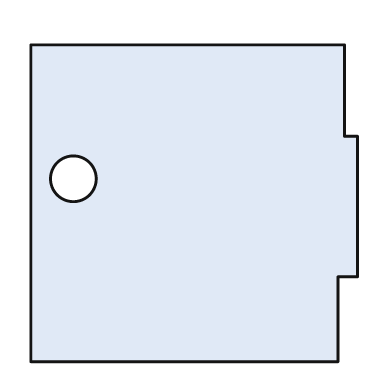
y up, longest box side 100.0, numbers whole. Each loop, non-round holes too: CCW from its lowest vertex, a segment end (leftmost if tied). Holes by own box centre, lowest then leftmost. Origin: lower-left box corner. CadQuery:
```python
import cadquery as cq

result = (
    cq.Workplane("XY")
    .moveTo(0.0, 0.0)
    .lineTo(94.0, 0.0)
    .lineTo(94.0, 26.0)
    .lineTo(100.0, 26.0)
    .lineTo(100.0, 69.0)
    .lineTo(96.0, 69.0)
    .lineTo(96.0, 97.0)
    .lineTo(0.0, 97.0)
    .close()
    .moveTo(13.0, 56.0)
    .circle(7.0)
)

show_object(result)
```